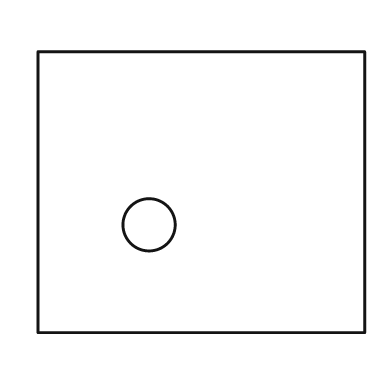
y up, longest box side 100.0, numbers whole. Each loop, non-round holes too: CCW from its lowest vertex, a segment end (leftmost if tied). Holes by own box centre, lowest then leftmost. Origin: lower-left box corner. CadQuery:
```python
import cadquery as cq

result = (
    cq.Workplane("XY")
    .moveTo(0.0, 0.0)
    .lineTo(100.0, 0.0)
    .lineTo(100.0, 86.0)
    .lineTo(0.0, 86.0)
    .close()
    .moveTo(34.0, 33.0)
    .circle(8.0)
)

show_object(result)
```